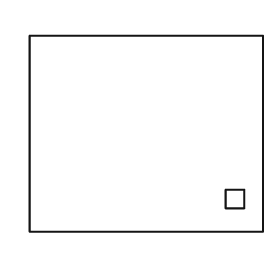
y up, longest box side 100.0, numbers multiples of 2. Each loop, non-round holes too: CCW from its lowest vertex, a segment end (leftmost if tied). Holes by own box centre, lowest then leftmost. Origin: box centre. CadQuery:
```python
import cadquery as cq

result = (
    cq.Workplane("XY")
    .moveTo(-50.0, -42.0)
    .lineTo(50.0, -42.0)
    .lineTo(50.0, 42.0)
    .lineTo(-50.0, 42.0)
    .close()
    .moveTo(34.0, -32.0)
    .lineTo(42.0, -32.0)
    .lineTo(42.0, -24.0)
    .lineTo(34.0, -24.0)
    .close()
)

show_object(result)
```